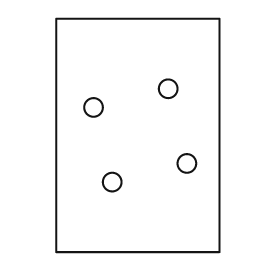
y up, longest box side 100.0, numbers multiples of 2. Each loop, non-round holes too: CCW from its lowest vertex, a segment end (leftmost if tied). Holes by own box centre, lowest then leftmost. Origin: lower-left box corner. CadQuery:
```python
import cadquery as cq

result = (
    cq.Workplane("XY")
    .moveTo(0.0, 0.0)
    .lineTo(70.0, 0.0)
    .lineTo(70.0, 100.0)
    .lineTo(0.0, 100.0)
    .close()
    .moveTo(24.0, 30.0)
    .circle(4.0)
    .moveTo(56.0, 38.0)
    .circle(4.0)
    .moveTo(16.0, 62.0)
    .circle(4.0)
    .moveTo(48.0, 70.0)
    .circle(4.0)
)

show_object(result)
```